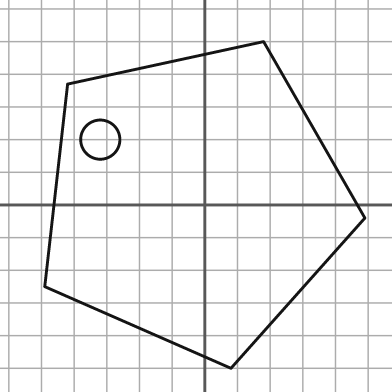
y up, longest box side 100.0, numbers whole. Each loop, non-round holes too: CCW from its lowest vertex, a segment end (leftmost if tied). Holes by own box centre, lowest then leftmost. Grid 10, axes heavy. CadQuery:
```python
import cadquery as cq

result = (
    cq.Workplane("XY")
    .moveTo(8.0, -50.0)
    .lineTo(49.0, -4.0)
    .lineTo(18.0, 50.0)
    .lineTo(-42.0, 37.0)
    .lineTo(-49.0, -25.0)
    .close()
    .moveTo(-32.0, 20.0)
    .circle(6.0)
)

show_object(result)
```